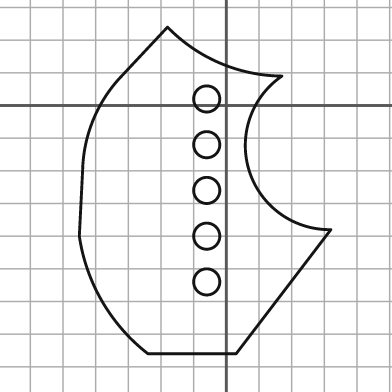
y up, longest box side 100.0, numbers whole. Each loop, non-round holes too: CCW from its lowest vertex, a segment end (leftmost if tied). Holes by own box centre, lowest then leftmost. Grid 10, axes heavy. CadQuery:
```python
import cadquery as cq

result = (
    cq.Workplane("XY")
    .moveTo(-24.0, -76.0)
    .lineTo(3.0, -76.0)
    .lineTo(32.0, -38.0)
    .threePointArc((7.0, -20.0), (17.0, 9.0))
    .threePointArc((-2.0, 13.0), (-18.0, 24.0))
    .lineTo(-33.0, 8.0)
    .threePointArc((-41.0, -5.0), (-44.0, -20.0))
    .lineTo(-45.0, -40.0)
    .threePointArc((-38.0, -60.0), (-24.0, -76.0))
    .close()
    .moveTo(-6.0, -54.0)
    .circle(4.0)
    .moveTo(-6.0, -40.0)
    .circle(4.0)
    .moveTo(-6.0, -26.0)
    .circle(4.0)
    .moveTo(-6.0, -12.0)
    .circle(4.0)
    .moveTo(-6.0, 2.0)
    .circle(4.0)
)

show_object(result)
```